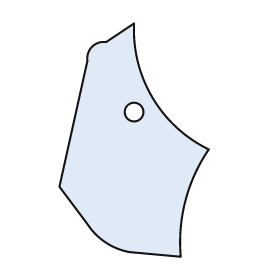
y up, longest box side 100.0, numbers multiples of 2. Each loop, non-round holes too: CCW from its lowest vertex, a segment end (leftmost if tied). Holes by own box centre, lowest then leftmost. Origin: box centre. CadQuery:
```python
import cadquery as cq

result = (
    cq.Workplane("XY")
    .moveTo(20.0, -50.0)
    .threePointArc((22.0, -26.0), (32.0, -4.0))
    .threePointArc((8.0, 18.0), (0.0, 50.0))
    .lineTo(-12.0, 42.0)
    .threePointArc((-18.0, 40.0), (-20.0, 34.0))
    .lineTo(-32.0, -20.0)
    .lineTo(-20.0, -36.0)
    .threePointArc((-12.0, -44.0), (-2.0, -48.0))
    .close()
    .moveTo(0.0, 12.0)
    .circle(4.0)
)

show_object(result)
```